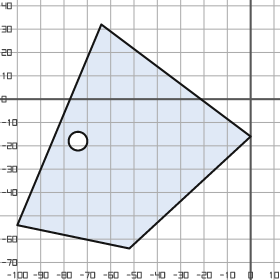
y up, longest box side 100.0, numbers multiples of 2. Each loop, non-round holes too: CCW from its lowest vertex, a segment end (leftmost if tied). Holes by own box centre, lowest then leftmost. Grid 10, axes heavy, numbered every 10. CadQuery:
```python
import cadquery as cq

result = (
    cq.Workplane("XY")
    .moveTo(-52.0, -64.0)
    .lineTo(0.0, -16.0)
    .lineTo(-64.0, 32.0)
    .lineTo(-100.0, -54.0)
    .close()
    .moveTo(-74.0, -18.0)
    .circle(4.0)
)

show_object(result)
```